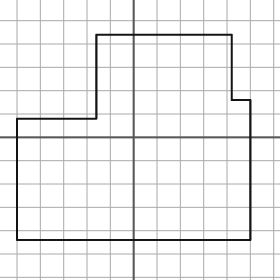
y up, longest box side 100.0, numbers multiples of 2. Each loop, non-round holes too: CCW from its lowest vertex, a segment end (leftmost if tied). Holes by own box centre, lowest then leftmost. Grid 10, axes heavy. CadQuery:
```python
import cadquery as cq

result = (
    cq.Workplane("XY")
    .moveTo(-50.0, -44.0)
    .lineTo(50.0, -44.0)
    .lineTo(50.0, 16.0)
    .lineTo(42.0, 16.0)
    .lineTo(42.0, 44.0)
    .lineTo(-16.0, 44.0)
    .lineTo(-16.0, 8.0)
    .lineTo(-50.0, 8.0)
    .close()
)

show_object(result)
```